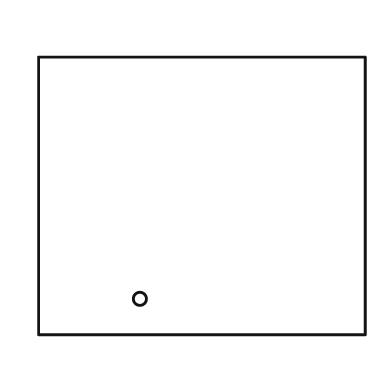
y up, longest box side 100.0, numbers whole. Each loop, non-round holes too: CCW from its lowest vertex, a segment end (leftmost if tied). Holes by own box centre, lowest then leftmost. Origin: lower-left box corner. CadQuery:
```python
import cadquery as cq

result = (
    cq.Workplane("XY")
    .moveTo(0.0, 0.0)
    .lineTo(100.0, 0.0)
    .lineTo(100.0, 85.0)
    .lineTo(0.0, 85.0)
    .close()
    .moveTo(31.0, 11.0)
    .circle(2.0)
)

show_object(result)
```